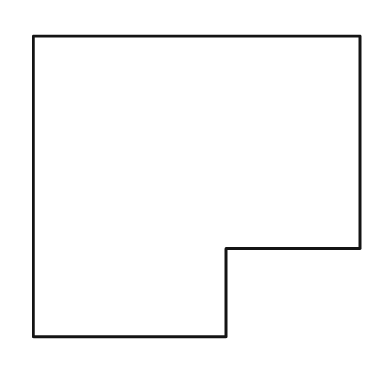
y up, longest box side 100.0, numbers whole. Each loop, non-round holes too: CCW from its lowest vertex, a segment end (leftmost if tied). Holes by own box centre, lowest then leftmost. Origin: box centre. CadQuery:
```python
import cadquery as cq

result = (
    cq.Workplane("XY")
    .moveTo(-50.0, -46.0)
    .lineTo(9.0, -46.0)
    .lineTo(9.0, -19.0)
    .lineTo(50.0, -19.0)
    .lineTo(50.0, 46.0)
    .lineTo(-50.0, 46.0)
    .close()
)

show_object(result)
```